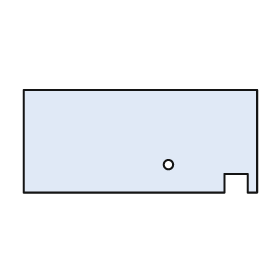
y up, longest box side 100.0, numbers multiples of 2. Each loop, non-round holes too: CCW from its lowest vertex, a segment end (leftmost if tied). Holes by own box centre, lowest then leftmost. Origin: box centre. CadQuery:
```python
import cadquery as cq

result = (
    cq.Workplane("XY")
    .moveTo(-50.0, -22.0)
    .lineTo(36.0, -22.0)
    .lineTo(36.0, -14.0)
    .lineTo(46.0, -14.0)
    .lineTo(46.0, -22.0)
    .lineTo(50.0, -22.0)
    .lineTo(50.0, 22.0)
    .lineTo(-50.0, 22.0)
    .close()
    .moveTo(12.0, -10.0)
    .circle(2.0)
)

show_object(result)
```